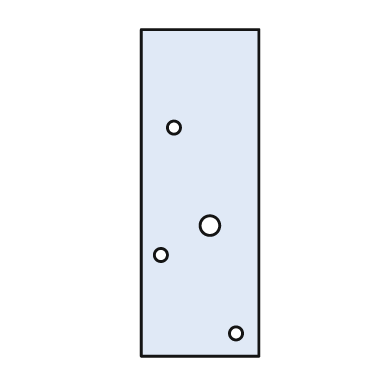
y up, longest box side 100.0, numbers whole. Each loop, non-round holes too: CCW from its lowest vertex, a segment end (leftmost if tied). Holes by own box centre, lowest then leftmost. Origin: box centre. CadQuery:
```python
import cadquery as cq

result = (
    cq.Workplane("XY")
    .moveTo(-18.0, -50.0)
    .lineTo(18.0, -50.0)
    .lineTo(18.0, 50.0)
    .lineTo(-18.0, 50.0)
    .close()
    .moveTo(11.0, -43.0)
    .circle(2.0)
    .moveTo(-12.0, -19.0)
    .circle(2.0)
    .moveTo(3.0, -10.0)
    .circle(3.0)
    .moveTo(-8.0, 20.0)
    .circle(2.0)
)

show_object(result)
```